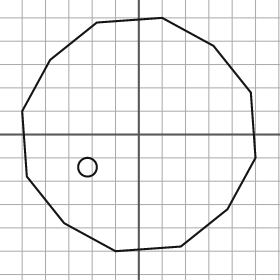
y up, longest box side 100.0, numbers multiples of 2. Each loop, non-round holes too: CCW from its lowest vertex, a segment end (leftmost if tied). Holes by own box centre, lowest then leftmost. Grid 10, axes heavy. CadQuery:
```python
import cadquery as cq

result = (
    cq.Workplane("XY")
    .moveTo(-10.0, -50.0)
    .lineTo(18.0, -48.0)
    .lineTo(38.0, -32.0)
    .lineTo(50.0, -10.0)
    .lineTo(48.0, 18.0)
    .lineTo(32.0, 38.0)
    .lineTo(10.0, 50.0)
    .lineTo(-18.0, 48.0)
    .lineTo(-38.0, 32.0)
    .lineTo(-50.0, 10.0)
    .lineTo(-48.0, -18.0)
    .lineTo(-32.0, -38.0)
    .close()
    .moveTo(-22.0, -14.0)
    .circle(4.0)
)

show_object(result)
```